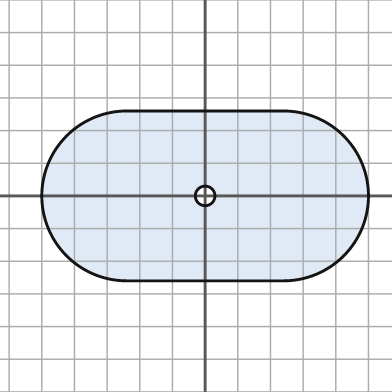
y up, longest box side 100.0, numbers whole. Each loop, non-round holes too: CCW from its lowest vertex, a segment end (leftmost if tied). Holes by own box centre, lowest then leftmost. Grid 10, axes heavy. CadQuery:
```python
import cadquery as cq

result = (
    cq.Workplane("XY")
    .moveTo(-24.0, -26.0)
    .lineTo(24.0, -26.0)
    .threePointArc((50.0, 0.0), (24.0, 26.0))
    .lineTo(-24.0, 26.0)
    .threePointArc((-50.0, 0.0), (-24.0, -26.0))
    .close()
    .moveTo(0.0, 0.0)
    .circle(3.0)
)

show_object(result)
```